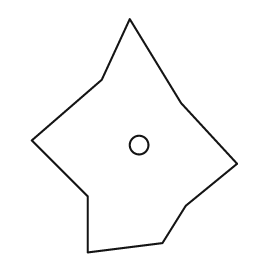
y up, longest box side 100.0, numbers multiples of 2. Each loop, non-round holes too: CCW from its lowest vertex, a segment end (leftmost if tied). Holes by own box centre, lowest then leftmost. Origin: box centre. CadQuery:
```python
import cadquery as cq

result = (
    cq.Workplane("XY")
    .moveTo(-20.0, -50.0)
    .lineTo(12.0, -46.0)
    .lineTo(22.0, -30.0)
    .lineTo(44.0, -12.0)
    .lineTo(20.0, 14.0)
    .lineTo(-2.0, 50.0)
    .lineTo(-14.0, 24.0)
    .lineTo(-44.0, -2.0)
    .lineTo(-20.0, -26.0)
    .close()
    .moveTo(2.0, -4.0)
    .circle(4.0)
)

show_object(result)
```